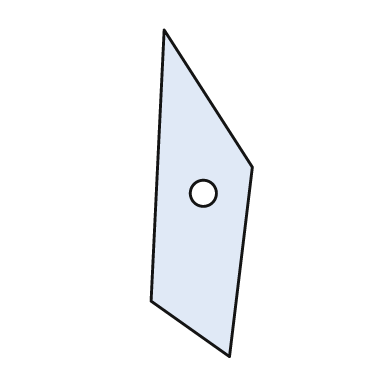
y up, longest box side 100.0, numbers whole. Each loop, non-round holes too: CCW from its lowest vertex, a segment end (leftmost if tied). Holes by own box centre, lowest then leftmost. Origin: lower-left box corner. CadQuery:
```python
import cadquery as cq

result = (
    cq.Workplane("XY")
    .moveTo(24.0, 0.0)
    .lineTo(31.0, 58.0)
    .lineTo(4.0, 100.0)
    .lineTo(0.0, 17.0)
    .close()
    .moveTo(16.0, 50.0)
    .circle(4.0)
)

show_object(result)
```